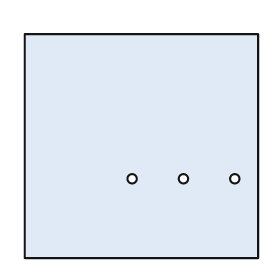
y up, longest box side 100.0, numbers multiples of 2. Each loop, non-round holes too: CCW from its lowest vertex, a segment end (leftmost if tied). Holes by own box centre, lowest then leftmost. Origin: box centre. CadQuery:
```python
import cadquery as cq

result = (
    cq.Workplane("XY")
    .moveTo(-50.0, -48.0)
    .lineTo(50.0, -48.0)
    .lineTo(50.0, 48.0)
    .lineTo(-50.0, 48.0)
    .close()
    .moveTo(-4.0, -14.0)
    .circle(2.0)
    .moveTo(18.0, -14.0)
    .circle(2.0)
    .moveTo(40.0, -14.0)
    .circle(2.0)
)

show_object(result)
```